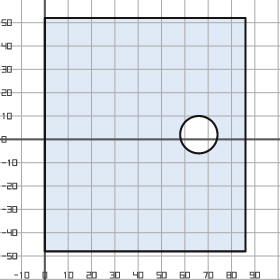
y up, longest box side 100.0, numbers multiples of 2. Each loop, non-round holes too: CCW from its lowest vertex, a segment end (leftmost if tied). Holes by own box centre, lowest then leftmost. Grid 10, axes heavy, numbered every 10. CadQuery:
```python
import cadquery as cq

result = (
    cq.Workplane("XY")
    .moveTo(0.0, -48.0)
    .lineTo(86.0, -48.0)
    .lineTo(86.0, 52.0)
    .lineTo(0.0, 52.0)
    .close()
    .moveTo(66.0, 2.0)
    .circle(8.0)
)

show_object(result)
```